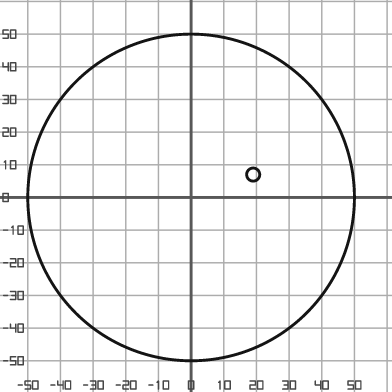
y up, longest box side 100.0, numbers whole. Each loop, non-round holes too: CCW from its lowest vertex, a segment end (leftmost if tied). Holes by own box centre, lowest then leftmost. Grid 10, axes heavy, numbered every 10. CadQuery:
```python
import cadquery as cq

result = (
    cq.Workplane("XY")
    .moveTo(0.0, 0.0)
    .circle(50.0)
    .moveTo(19.0, 7.0)
    .circle(2.0)
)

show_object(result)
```